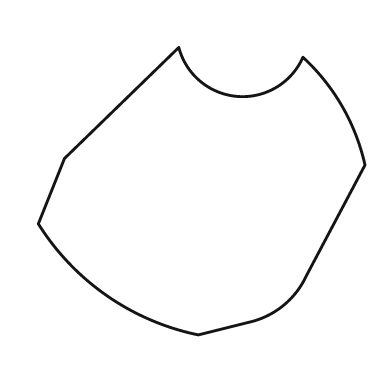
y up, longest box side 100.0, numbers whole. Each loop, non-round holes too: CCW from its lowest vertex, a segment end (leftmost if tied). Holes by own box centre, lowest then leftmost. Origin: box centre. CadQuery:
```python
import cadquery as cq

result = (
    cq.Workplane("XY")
    .moveTo(-1.0, -44.0)
    .lineTo(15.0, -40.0)
    .threePointArc((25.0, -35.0), (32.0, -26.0))
    .lineTo(50.0, 8.0)
    .threePointArc((43.0, 26.0), (31.0, 41.0))
    .threePointArc((11.0, 29.0), (-7.0, 44.0))
    .lineTo(-42.0, 10.0)
    .lineTo(-50.0, -10.0)
    .threePointArc((-29.0, -32.0), (-1.0, -44.0))
    .close()
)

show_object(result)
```